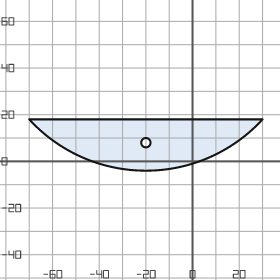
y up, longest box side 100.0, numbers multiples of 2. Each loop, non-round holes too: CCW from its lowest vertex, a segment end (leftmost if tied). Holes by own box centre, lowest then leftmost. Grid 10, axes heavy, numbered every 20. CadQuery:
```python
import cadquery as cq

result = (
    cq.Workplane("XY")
    .moveTo(-70.0, 18.0)
    .threePointArc((-20.0, -4.0), (30.0, 18.0))
    .close()
    .moveTo(-20.0, 8.0)
    .circle(2.0)
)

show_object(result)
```